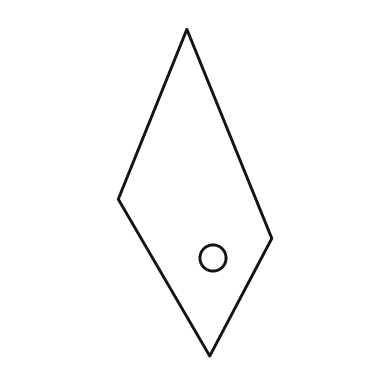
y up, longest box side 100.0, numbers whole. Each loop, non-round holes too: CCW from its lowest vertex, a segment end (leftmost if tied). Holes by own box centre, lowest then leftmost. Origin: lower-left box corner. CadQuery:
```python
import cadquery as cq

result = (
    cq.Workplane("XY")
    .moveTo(28.0, 0.0)
    .lineTo(47.0, 36.0)
    .lineTo(21.0, 100.0)
    .lineTo(0.0, 48.0)
    .close()
    .moveTo(29.0, 30.0)
    .circle(4.0)
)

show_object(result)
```